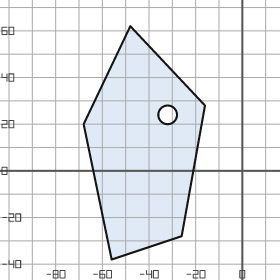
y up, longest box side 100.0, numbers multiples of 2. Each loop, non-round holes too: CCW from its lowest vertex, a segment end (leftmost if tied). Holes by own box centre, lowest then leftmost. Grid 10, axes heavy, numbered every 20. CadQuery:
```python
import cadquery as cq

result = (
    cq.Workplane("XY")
    .moveTo(-56.0, -38.0)
    .lineTo(-26.0, -28.0)
    .lineTo(-16.0, 28.0)
    .lineTo(-48.0, 62.0)
    .lineTo(-68.0, 20.0)
    .close()
    .moveTo(-32.0, 24.0)
    .circle(4.0)
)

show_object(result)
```